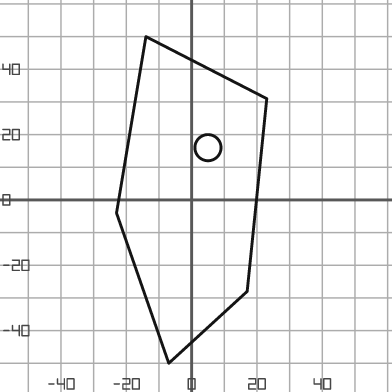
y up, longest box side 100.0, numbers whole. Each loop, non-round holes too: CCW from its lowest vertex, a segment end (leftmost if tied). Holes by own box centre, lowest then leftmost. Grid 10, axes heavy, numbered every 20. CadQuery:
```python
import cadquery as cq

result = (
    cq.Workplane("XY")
    .moveTo(-7.0, -50.0)
    .lineTo(17.0, -28.0)
    .lineTo(23.0, 31.0)
    .lineTo(-14.0, 50.0)
    .lineTo(-23.0, -4.0)
    .close()
    .moveTo(5.0, 16.0)
    .circle(4.0)
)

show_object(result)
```